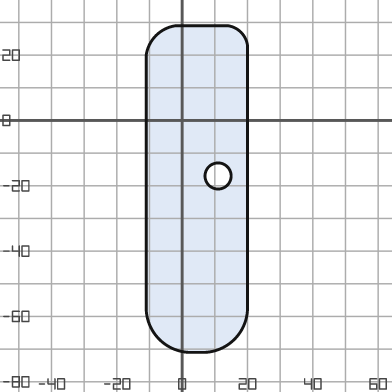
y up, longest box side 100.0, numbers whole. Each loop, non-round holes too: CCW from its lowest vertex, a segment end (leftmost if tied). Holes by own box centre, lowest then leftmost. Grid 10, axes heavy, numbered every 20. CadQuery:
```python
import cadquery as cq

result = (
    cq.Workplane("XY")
    .moveTo(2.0, -71.0)
    .lineTo(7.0, -71.0)
    .threePointArc((16.0, -67.0), (20.0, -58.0))
    .lineTo(20.0, 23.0)
    .threePointArc((18.0, 27.0), (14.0, 29.0))
    .lineTo(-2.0, 29.0)
    .threePointArc((-8.0, 26.0), (-11.0, 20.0))
    .lineTo(-11.0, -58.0)
    .threePointArc((-7.0, -67.0), (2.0, -71.0))
    .close()
    .moveTo(11.0, -17.0)
    .circle(4.0)
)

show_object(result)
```